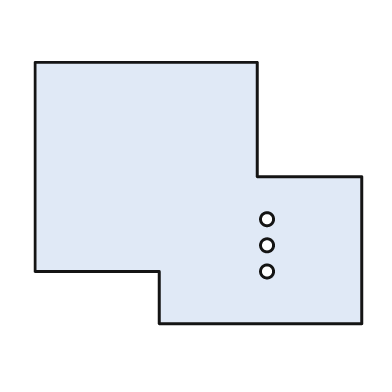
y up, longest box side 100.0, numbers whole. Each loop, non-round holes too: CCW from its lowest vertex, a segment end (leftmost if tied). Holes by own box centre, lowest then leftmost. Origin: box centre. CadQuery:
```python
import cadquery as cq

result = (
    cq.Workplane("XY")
    .moveTo(-12.0, -40.0)
    .lineTo(50.0, -40.0)
    .lineTo(50.0, 5.0)
    .lineTo(18.0, 5.0)
    .lineTo(18.0, 40.0)
    .lineTo(-50.0, 40.0)
    .lineTo(-50.0, -24.0)
    .lineTo(-12.0, -24.0)
    .close()
    .moveTo(21.0, -24.0)
    .circle(2.0)
    .moveTo(21.0, -16.0)
    .circle(2.0)
    .moveTo(21.0, -8.0)
    .circle(2.0)
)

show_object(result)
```